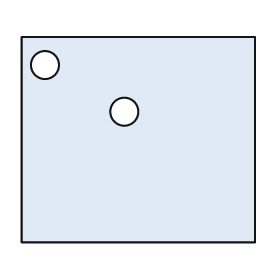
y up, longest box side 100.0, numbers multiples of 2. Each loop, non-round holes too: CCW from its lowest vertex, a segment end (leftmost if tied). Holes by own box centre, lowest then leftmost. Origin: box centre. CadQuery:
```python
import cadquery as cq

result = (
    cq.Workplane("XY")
    .moveTo(-50.0, -44.0)
    .lineTo(50.0, -44.0)
    .lineTo(50.0, 44.0)
    .lineTo(-50.0, 44.0)
    .close()
    .moveTo(-6.0, 12.0)
    .circle(6.0)
    .moveTo(-40.0, 32.0)
    .circle(6.0)
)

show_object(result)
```